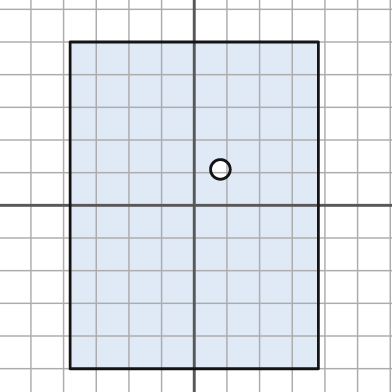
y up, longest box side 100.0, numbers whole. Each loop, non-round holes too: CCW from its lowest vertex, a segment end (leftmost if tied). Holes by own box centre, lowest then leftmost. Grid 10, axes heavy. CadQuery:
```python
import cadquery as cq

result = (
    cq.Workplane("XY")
    .moveTo(-38.0, -50.0)
    .lineTo(38.0, -50.0)
    .lineTo(38.0, 50.0)
    .lineTo(-38.0, 50.0)
    .close()
    .moveTo(8.0, 11.0)
    .circle(3.0)
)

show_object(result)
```